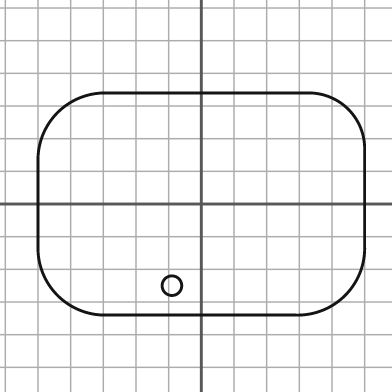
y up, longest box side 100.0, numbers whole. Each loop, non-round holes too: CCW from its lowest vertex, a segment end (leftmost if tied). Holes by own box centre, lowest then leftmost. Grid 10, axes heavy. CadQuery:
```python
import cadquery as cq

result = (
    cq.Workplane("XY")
    .moveTo(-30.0, -34.0)
    .lineTo(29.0, -34.0)
    .threePointArc((44.0, -28.0), (50.0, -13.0))
    .lineTo(50.0, 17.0)
    .threePointArc((45.0, 29.0), (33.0, 34.0))
    .lineTo(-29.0, 34.0)
    .threePointArc((-44.0, 28.0), (-50.0, 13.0))
    .lineTo(-50.0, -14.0)
    .threePointArc((-44.0, -28.0), (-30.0, -34.0))
    .close()
    .moveTo(-9.0, -25.0)
    .circle(3.0)
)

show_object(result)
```